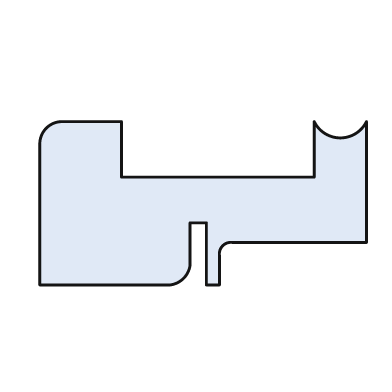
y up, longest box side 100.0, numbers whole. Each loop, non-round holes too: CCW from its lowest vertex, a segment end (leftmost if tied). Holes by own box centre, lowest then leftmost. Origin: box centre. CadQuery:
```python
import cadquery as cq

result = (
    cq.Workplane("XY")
    .moveTo(-50.0, -25.0)
    .lineTo(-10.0, -25.0)
    .threePointArc((-6.0, -23.0), (-4.0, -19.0))
    .lineTo(-4.0, -6.0)
    .lineTo(1.0, -6.0)
    .lineTo(1.0, -25.0)
    .lineTo(5.0, -25.0)
    .lineTo(5.0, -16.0)
    .threePointArc((6.0, -13.0), (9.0, -12.0))
    .lineTo(50.0, -12.0)
    .lineTo(50.0, 25.0)
    .threePointArc((42.0, 20.0), (34.0, 25.0))
    .lineTo(34.0, 8.0)
    .lineTo(-25.0, 8.0)
    .lineTo(-25.0, 25.0)
    .lineTo(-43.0, 25.0)
    .threePointArc((-48.0, 23.0), (-50.0, 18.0))
    .close()
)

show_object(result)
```